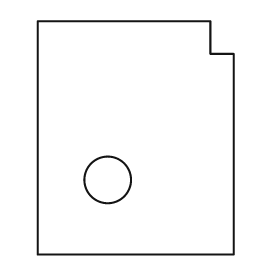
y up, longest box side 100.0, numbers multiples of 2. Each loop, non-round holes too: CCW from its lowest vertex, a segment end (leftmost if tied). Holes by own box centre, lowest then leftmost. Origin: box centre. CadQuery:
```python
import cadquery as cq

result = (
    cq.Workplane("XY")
    .moveTo(-42.0, -50.0)
    .lineTo(42.0, -50.0)
    .lineTo(42.0, 36.0)
    .lineTo(32.0, 36.0)
    .lineTo(32.0, 50.0)
    .lineTo(-42.0, 50.0)
    .close()
    .moveTo(-12.0, -18.0)
    .circle(10.0)
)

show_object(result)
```